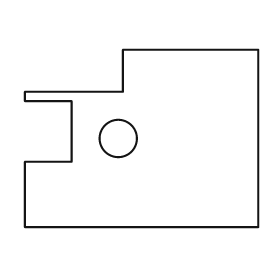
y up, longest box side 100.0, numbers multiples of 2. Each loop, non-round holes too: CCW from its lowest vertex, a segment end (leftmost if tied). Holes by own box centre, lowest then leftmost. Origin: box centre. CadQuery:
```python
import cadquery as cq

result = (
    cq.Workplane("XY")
    .moveTo(-50.0, -38.0)
    .lineTo(50.0, -38.0)
    .lineTo(50.0, 38.0)
    .lineTo(-8.0, 38.0)
    .lineTo(-8.0, 20.0)
    .lineTo(-50.0, 20.0)
    .lineTo(-50.0, 16.0)
    .lineTo(-30.0, 16.0)
    .lineTo(-30.0, -10.0)
    .lineTo(-50.0, -10.0)
    .close()
    .moveTo(-10.0, 0.0)
    .circle(8.0)
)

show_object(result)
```